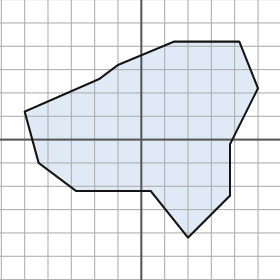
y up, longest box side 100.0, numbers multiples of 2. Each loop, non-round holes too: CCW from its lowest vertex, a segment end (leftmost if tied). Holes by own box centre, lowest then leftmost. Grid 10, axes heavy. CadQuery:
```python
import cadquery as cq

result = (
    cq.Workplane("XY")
    .moveTo(20.0, -42.0)
    .lineTo(38.0, -24.0)
    .lineTo(38.0, -2.0)
    .lineTo(50.0, 22.0)
    .lineTo(42.0, 42.0)
    .lineTo(14.0, 42.0)
    .lineTo(-10.0, 32.0)
    .lineTo(-18.0, 26.0)
    .lineTo(-50.0, 12.0)
    .lineTo(-44.0, -10.0)
    .lineTo(-28.0, -22.0)
    .lineTo(4.0, -22.0)
    .close()
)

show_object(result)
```